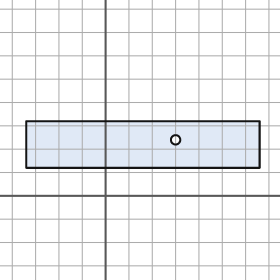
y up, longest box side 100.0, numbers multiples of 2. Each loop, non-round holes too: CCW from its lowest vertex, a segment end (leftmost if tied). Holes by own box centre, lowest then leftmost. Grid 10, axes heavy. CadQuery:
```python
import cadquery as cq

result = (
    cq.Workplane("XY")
    .moveTo(-34.0, 12.0)
    .lineTo(66.0, 12.0)
    .lineTo(66.0, 32.0)
    .lineTo(-34.0, 32.0)
    .close()
    .moveTo(30.0, 24.0)
    .circle(2.0)
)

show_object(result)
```